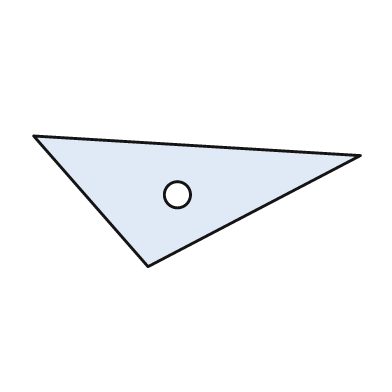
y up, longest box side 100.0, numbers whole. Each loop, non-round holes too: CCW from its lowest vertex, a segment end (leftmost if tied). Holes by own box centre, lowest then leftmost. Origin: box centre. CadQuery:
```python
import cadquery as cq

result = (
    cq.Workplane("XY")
    .moveTo(-15.0, -20.0)
    .lineTo(50.0, 14.0)
    .lineTo(-50.0, 20.0)
    .close()
    .moveTo(-6.0, 2.0)
    .circle(4.0)
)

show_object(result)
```